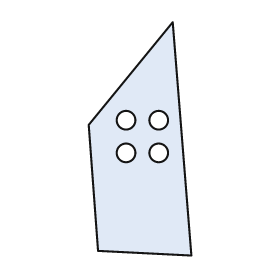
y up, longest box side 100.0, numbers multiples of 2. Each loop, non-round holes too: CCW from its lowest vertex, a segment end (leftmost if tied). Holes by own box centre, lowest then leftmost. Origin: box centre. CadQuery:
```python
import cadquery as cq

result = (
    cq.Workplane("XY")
    .moveTo(22.0, -50.0)
    .lineTo(14.0, 50.0)
    .lineTo(-22.0, 6.0)
    .lineTo(-18.0, -48.0)
    .close()
    .moveTo(-6.0, -6.0)
    .circle(4.0)
    .moveTo(8.0, -6.0)
    .circle(4.0)
    .moveTo(-6.0, 8.0)
    .circle(4.0)
    .moveTo(8.0, 8.0)
    .circle(4.0)
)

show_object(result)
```